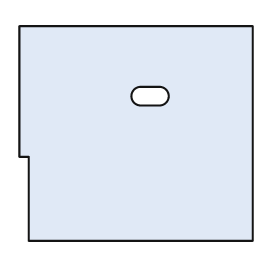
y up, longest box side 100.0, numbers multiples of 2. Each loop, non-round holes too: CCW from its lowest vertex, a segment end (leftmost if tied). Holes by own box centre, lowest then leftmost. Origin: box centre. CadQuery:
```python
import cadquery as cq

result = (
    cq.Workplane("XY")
    .moveTo(-46.0, -46.0)
    .lineTo(50.0, -46.0)
    .lineTo(50.0, 46.0)
    .lineTo(-50.0, 46.0)
    .lineTo(-50.0, -10.0)
    .lineTo(-46.0, -10.0)
    .close()
    .moveTo(2.0, 12.0)
    .lineTo(10.0, 12.0)
    .threePointArc((14.0, 16.0), (10.0, 20.0))
    .lineTo(2.0, 20.0)
    .threePointArc((-2.0, 16.0), (2.0, 12.0))
    .close()
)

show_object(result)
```